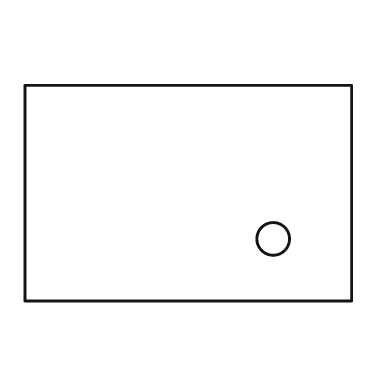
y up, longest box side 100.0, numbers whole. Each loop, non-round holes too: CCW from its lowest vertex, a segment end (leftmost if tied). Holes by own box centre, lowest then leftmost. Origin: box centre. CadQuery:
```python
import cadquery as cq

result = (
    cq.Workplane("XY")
    .moveTo(-50.0, -33.0)
    .lineTo(50.0, -33.0)
    .lineTo(50.0, 33.0)
    .lineTo(-50.0, 33.0)
    .close()
    .moveTo(26.0, -14.0)
    .circle(5.0)
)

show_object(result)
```